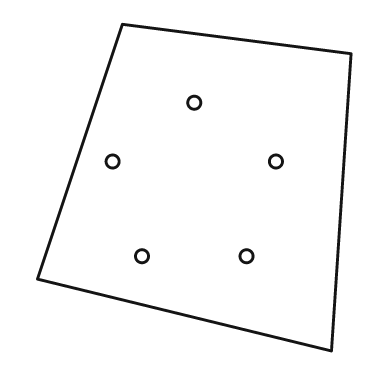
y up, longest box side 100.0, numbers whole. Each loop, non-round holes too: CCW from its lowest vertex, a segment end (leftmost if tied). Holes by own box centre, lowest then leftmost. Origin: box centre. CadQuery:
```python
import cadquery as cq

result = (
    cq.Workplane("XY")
    .moveTo(42.0, -50.0)
    .lineTo(48.0, 41.0)
    .lineTo(-22.0, 50.0)
    .lineTo(-48.0, -28.0)
    .close()
    .moveTo(-16.0, -21.0)
    .circle(2.0)
    .moveTo(16.0, -21.0)
    .circle(2.0)
    .moveTo(-25.0, 8.0)
    .circle(2.0)
    .moveTo(25.0, 8.0)
    .circle(2.0)
    .moveTo(0.0, 26.0)
    .circle(2.0)
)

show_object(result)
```